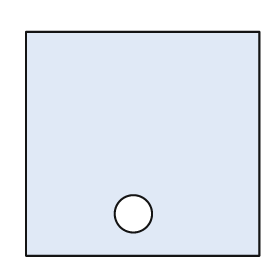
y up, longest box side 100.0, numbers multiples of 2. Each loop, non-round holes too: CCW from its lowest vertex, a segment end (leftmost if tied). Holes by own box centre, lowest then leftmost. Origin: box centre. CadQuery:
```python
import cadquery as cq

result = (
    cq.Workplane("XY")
    .moveTo(-50.0, -48.0)
    .lineTo(50.0, -48.0)
    .lineTo(50.0, 48.0)
    .lineTo(-50.0, 48.0)
    .close()
    .moveTo(-4.0, -30.0)
    .circle(8.0)
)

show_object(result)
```